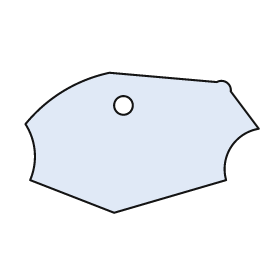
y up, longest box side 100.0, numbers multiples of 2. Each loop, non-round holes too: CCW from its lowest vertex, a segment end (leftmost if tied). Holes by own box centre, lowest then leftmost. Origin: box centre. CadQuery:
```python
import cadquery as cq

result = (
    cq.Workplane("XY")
    .moveTo(-12.0, -30.0)
    .lineTo(36.0, -16.0)
    .threePointArc((38.0, -2.0), (50.0, 6.0))
    .lineTo(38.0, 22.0)
    .threePointArc((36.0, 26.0), (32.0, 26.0))
    .lineTo(-14.0, 30.0)
    .threePointArc((-34.0, 22.0), (-50.0, 8.0))
    .threePointArc((-46.0, -4.0), (-48.0, -16.0))
    .close()
    .moveTo(-8.0, 16.0)
    .circle(4.0)
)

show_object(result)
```